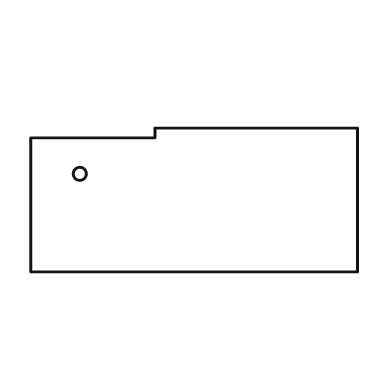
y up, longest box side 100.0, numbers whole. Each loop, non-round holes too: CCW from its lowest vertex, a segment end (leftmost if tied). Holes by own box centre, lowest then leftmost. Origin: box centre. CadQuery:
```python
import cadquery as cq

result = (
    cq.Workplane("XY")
    .moveTo(-50.0, -22.0)
    .lineTo(50.0, -22.0)
    .lineTo(50.0, 22.0)
    .lineTo(-12.0, 22.0)
    .lineTo(-12.0, 19.0)
    .lineTo(-50.0, 19.0)
    .close()
    .moveTo(-35.0, 8.0)
    .circle(2.0)
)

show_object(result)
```